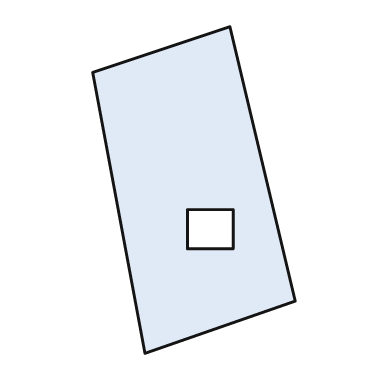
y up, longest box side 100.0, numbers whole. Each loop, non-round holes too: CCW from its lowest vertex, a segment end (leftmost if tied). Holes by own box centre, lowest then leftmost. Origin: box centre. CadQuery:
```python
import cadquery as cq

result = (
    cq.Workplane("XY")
    .moveTo(-15.0, -50.0)
    .lineTo(31.0, -34.0)
    .lineTo(11.0, 50.0)
    .lineTo(-31.0, 36.0)
    .close()
    .moveTo(-2.0, -18.0)
    .lineTo(12.0, -18.0)
    .lineTo(12.0, -6.0)
    .lineTo(-2.0, -6.0)
    .close()
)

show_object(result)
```